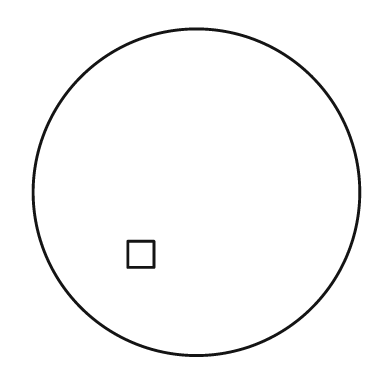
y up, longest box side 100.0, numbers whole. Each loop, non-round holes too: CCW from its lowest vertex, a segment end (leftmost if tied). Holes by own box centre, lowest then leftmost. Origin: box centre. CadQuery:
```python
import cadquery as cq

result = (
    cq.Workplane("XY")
    .moveTo(0.0, 0.0)
    .circle(50.0)
    .moveTo(-21.0, -23.0)
    .lineTo(-13.0, -23.0)
    .lineTo(-13.0, -15.0)
    .lineTo(-21.0, -15.0)
    .close()
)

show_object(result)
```